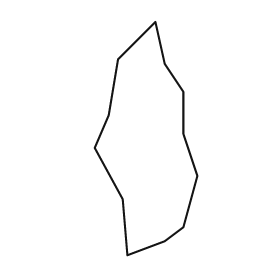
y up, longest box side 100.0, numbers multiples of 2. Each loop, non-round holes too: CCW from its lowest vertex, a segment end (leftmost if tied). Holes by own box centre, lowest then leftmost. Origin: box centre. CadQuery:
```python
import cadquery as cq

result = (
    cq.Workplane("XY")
    .moveTo(-8.0, -50.0)
    .lineTo(8.0, -44.0)
    .lineTo(16.0, -38.0)
    .lineTo(22.0, -16.0)
    .lineTo(16.0, 2.0)
    .lineTo(16.0, 20.0)
    .lineTo(8.0, 32.0)
    .lineTo(4.0, 50.0)
    .lineTo(-12.0, 34.0)
    .lineTo(-16.0, 10.0)
    .lineTo(-22.0, -4.0)
    .lineTo(-10.0, -26.0)
    .close()
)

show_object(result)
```